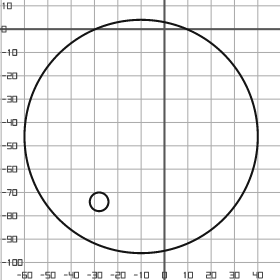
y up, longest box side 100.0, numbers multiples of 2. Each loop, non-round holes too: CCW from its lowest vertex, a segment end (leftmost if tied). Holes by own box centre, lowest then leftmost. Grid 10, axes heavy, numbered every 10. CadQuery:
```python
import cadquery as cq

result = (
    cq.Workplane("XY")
    .moveTo(-10.0, -46.0)
    .circle(50.0)
    .moveTo(-28.0, -74.0)
    .circle(4.0)
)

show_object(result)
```